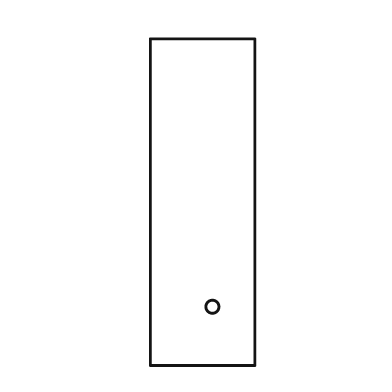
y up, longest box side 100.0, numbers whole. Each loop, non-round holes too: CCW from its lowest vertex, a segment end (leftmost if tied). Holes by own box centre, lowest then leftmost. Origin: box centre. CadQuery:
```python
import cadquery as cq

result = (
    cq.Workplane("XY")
    .moveTo(-16.0, -50.0)
    .lineTo(16.0, -50.0)
    .lineTo(16.0, 50.0)
    .lineTo(-16.0, 50.0)
    .close()
    .moveTo(3.0, -32.0)
    .circle(2.0)
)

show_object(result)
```